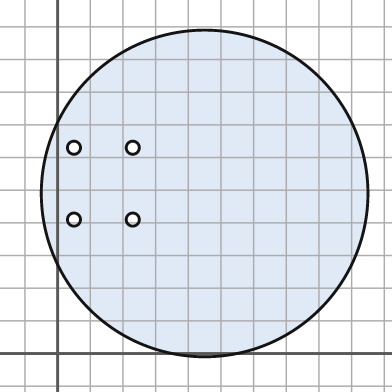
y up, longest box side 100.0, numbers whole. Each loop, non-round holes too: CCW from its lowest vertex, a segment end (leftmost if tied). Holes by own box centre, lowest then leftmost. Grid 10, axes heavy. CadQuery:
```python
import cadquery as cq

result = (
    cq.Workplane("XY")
    .moveTo(45.0, 49.0)
    .circle(50.0)
    .moveTo(5.0, 41.0)
    .circle(2.0)
    .moveTo(23.0, 41.0)
    .circle(2.0)
    .moveTo(5.0, 63.0)
    .circle(2.0)
    .moveTo(23.0, 63.0)
    .circle(2.0)
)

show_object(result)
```